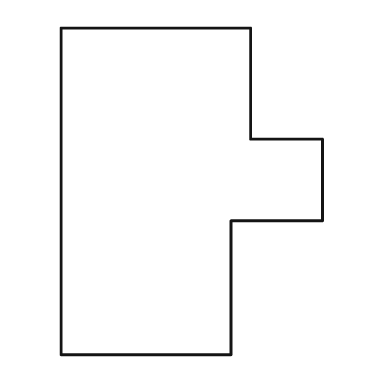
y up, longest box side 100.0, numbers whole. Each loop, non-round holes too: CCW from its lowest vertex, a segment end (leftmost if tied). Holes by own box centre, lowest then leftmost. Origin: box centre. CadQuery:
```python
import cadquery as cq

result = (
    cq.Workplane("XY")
    .moveTo(-40.0, -50.0)
    .lineTo(12.0, -50.0)
    .lineTo(12.0, -9.0)
    .lineTo(40.0, -9.0)
    .lineTo(40.0, 16.0)
    .lineTo(18.0, 16.0)
    .lineTo(18.0, 50.0)
    .lineTo(-40.0, 50.0)
    .close()
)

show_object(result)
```